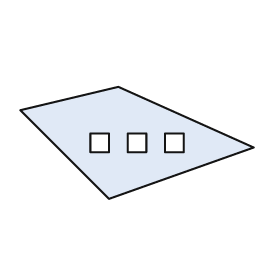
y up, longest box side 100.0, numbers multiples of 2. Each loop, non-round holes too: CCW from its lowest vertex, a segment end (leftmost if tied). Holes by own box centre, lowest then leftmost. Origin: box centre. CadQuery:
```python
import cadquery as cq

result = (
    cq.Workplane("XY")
    .moveTo(-12.0, -24.0)
    .lineTo(50.0, -2.0)
    .lineTo(-8.0, 24.0)
    .lineTo(-50.0, 14.0)
    .close()
    .moveTo(-20.0, -4.0)
    .lineTo(-12.0, -4.0)
    .lineTo(-12.0, 4.0)
    .lineTo(-20.0, 4.0)
    .close()
    .moveTo(-4.0, -4.0)
    .lineTo(4.0, -4.0)
    .lineTo(4.0, 4.0)
    .lineTo(-4.0, 4.0)
    .close()
    .moveTo(12.0, -4.0)
    .lineTo(20.0, -4.0)
    .lineTo(20.0, 4.0)
    .lineTo(12.0, 4.0)
    .close()
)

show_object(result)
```